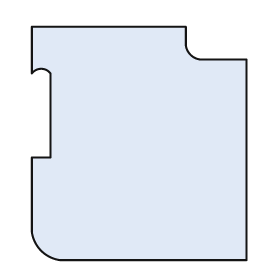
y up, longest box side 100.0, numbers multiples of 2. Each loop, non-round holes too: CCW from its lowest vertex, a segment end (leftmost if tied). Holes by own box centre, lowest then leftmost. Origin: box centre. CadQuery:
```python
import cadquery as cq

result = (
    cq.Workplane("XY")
    .moveTo(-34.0, -50.0)
    .lineTo(46.0, -50.0)
    .lineTo(46.0, 36.0)
    .lineTo(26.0, 36.0)
    .threePointArc((22.0, 38.0), (20.0, 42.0))
    .lineTo(20.0, 50.0)
    .lineTo(-46.0, 50.0)
    .lineTo(-46.0, 30.0)
    .threePointArc((-42.0, 32.0), (-38.0, 30.0))
    .lineTo(-38.0, -6.0)
    .lineTo(-46.0, -6.0)
    .lineTo(-46.0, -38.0)
    .threePointArc((-42.0, -46.0), (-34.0, -50.0))
    .close()
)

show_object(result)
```